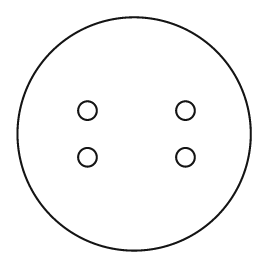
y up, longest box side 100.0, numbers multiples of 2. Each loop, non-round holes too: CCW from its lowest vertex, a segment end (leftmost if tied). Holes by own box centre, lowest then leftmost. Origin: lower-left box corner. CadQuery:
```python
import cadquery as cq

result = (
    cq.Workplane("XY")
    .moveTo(50.0, 50.0)
    .circle(50.0)
    .moveTo(30.0, 40.0)
    .circle(4.0)
    .moveTo(72.0, 40.0)
    .circle(4.0)
    .moveTo(30.0, 60.0)
    .circle(4.0)
    .moveTo(72.0, 60.0)
    .circle(4.0)
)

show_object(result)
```